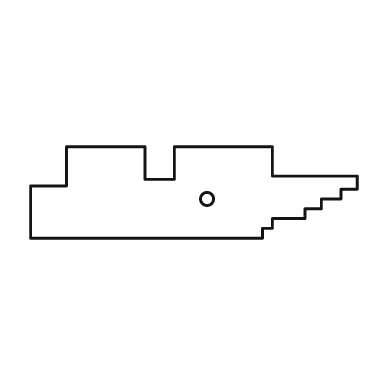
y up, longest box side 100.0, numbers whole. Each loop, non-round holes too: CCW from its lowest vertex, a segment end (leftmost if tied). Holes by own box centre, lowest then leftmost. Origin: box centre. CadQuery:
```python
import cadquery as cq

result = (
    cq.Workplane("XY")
    .moveTo(-50.0, -14.0)
    .lineTo(21.0, -14.0)
    .lineTo(21.0, -11.0)
    .lineTo(24.0, -11.0)
    .lineTo(24.0, -8.0)
    .lineTo(34.0, -8.0)
    .lineTo(34.0, -5.0)
    .lineTo(39.0, -5.0)
    .lineTo(39.0, -2.0)
    .lineTo(45.0, -2.0)
    .lineTo(45.0, 1.0)
    .lineTo(50.0, 1.0)
    .lineTo(50.0, 5.0)
    .lineTo(24.0, 5.0)
    .lineTo(24.0, 14.0)
    .lineTo(-6.0, 14.0)
    .lineTo(-6.0, 4.0)
    .lineTo(-15.0, 4.0)
    .lineTo(-15.0, 14.0)
    .lineTo(-39.0, 14.0)
    .lineTo(-39.0, 2.0)
    .lineTo(-50.0, 2.0)
    .close()
    .moveTo(4.0, -2.0)
    .circle(2.0)
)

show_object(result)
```